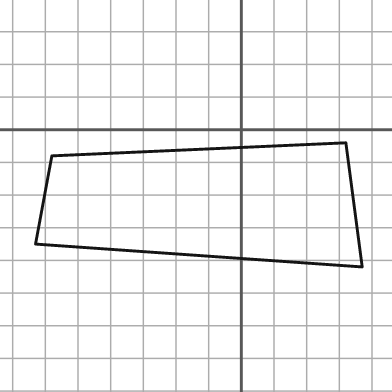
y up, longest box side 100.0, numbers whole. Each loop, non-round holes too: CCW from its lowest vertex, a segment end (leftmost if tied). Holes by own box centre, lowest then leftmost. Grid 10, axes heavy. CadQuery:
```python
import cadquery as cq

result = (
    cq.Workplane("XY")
    .moveTo(37.0, -42.0)
    .lineTo(32.0, -4.0)
    .lineTo(-58.0, -8.0)
    .lineTo(-63.0, -35.0)
    .close()
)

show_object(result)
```